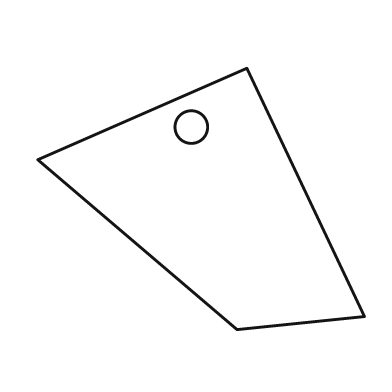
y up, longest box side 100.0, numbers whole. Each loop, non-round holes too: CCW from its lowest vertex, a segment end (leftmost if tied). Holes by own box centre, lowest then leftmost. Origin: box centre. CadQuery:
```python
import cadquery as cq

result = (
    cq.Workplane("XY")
    .moveTo(11.0, -40.0)
    .lineTo(50.0, -36.0)
    .lineTo(14.0, 40.0)
    .lineTo(-50.0, 12.0)
    .close()
    .moveTo(-3.0, 22.0)
    .circle(5.0)
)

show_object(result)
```